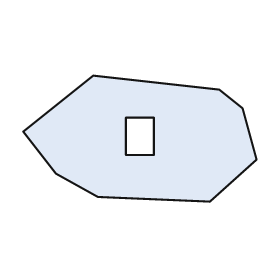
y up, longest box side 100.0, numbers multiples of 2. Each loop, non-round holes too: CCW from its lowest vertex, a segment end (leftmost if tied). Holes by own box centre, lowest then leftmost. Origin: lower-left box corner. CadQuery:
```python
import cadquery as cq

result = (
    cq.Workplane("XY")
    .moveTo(80.0, 0.0)
    .lineTo(100.0, 18.0)
    .lineTo(94.0, 40.0)
    .lineTo(84.0, 48.0)
    .lineTo(30.0, 54.0)
    .lineTo(0.0, 30.0)
    .lineTo(14.0, 12.0)
    .lineTo(32.0, 2.0)
    .close()
    .moveTo(44.0, 20.0)
    .lineTo(56.0, 20.0)
    .lineTo(56.0, 36.0)
    .lineTo(44.0, 36.0)
    .close()
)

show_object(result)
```